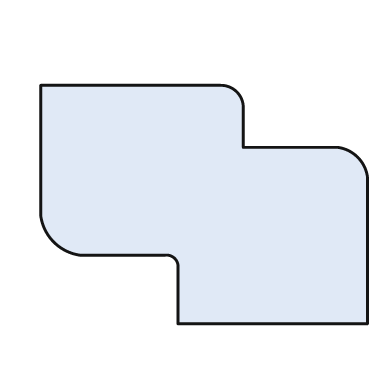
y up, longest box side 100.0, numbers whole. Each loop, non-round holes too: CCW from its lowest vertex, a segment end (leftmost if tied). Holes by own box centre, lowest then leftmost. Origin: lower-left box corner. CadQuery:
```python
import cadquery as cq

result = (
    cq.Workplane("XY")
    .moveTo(42.0, 0.0)
    .lineTo(100.0, 0.0)
    .lineTo(100.0, 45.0)
    .threePointArc((97.0, 51.0), (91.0, 54.0))
    .lineTo(62.0, 54.0)
    .lineTo(62.0, 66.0)
    .threePointArc((60.0, 71.0), (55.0, 73.0))
    .lineTo(0.0, 73.0)
    .lineTo(0.0, 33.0)
    .threePointArc((4.0, 25.0), (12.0, 21.0))
    .lineTo(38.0, 21.0)
    .threePointArc((41.0, 20.0), (42.0, 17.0))
    .close()
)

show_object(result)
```